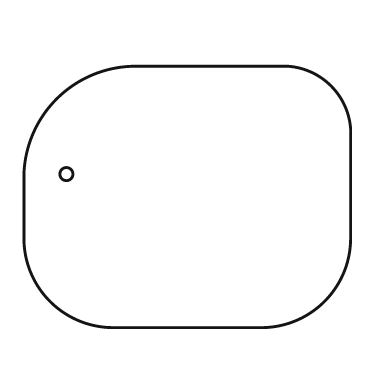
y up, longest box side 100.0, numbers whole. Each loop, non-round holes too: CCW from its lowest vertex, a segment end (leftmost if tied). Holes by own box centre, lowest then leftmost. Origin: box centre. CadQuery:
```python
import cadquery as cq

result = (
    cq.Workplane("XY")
    .moveTo(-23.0, -40.0)
    .lineTo(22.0, -40.0)
    .threePointArc((42.0, -32.0), (50.0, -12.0))
    .lineTo(50.0, 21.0)
    .threePointArc((44.0, 34.0), (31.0, 40.0))
    .lineTo(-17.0, 40.0)
    .threePointArc((-40.0, 30.0), (-50.0, 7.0))
    .lineTo(-50.0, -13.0)
    .threePointArc((-42.0, -32.0), (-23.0, -40.0))
    .close()
    .moveTo(-37.0, 7.0)
    .circle(2.0)
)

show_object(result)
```